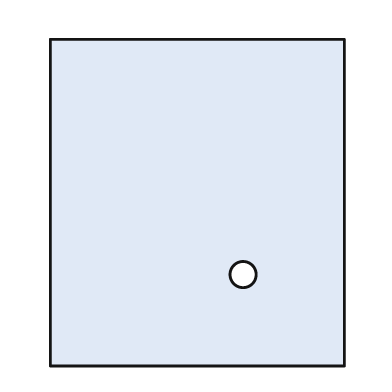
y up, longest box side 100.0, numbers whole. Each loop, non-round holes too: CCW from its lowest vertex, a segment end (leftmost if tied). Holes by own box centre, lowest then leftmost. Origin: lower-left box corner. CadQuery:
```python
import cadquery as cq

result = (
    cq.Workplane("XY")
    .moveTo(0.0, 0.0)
    .lineTo(90.0, 0.0)
    .lineTo(90.0, 100.0)
    .lineTo(0.0, 100.0)
    .close()
    .moveTo(59.0, 28.0)
    .circle(4.0)
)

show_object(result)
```